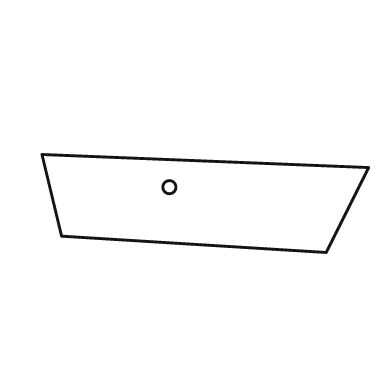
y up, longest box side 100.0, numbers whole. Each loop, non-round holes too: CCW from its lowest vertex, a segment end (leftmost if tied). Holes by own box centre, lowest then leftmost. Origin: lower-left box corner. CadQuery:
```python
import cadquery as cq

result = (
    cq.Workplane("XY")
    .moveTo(87.0, 0.0)
    .lineTo(100.0, 26.0)
    .lineTo(0.0, 30.0)
    .lineTo(6.0, 5.0)
    .close()
    .moveTo(39.0, 20.0)
    .circle(2.0)
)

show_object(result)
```